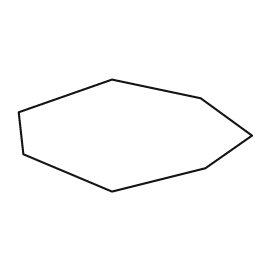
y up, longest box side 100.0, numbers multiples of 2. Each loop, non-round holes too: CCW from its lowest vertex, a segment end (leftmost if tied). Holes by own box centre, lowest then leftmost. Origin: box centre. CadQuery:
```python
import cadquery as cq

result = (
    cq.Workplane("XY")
    .moveTo(-10.0, -24.0)
    .lineTo(30.0, -14.0)
    .lineTo(50.0, 0.0)
    .lineTo(28.0, 16.0)
    .lineTo(-10.0, 24.0)
    .lineTo(-50.0, 10.0)
    .lineTo(-48.0, -8.0)
    .close()
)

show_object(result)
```